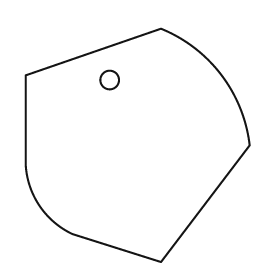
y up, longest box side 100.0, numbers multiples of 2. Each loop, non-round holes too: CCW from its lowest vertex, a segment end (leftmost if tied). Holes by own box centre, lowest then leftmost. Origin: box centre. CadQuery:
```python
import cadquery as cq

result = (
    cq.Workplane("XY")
    .moveTo(10.0, -50.0)
    .lineTo(48.0, 0.0)
    .threePointArc((36.0, 30.0), (10.0, 50.0))
    .lineTo(-48.0, 30.0)
    .lineTo(-48.0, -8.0)
    .threePointArc((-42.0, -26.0), (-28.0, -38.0))
    .close()
    .moveTo(-12.0, 28.0)
    .circle(4.0)
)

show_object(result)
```